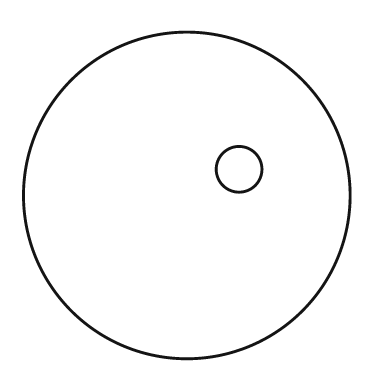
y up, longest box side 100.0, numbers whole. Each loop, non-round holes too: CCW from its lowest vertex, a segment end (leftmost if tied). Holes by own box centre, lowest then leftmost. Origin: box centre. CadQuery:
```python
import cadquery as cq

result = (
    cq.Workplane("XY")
    .moveTo(0.0, 0.0)
    .circle(50.0)
    .moveTo(16.0, 8.0)
    .circle(7.0)
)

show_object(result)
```